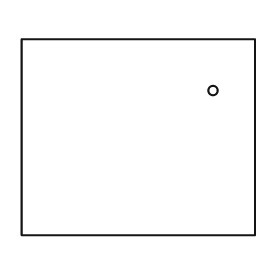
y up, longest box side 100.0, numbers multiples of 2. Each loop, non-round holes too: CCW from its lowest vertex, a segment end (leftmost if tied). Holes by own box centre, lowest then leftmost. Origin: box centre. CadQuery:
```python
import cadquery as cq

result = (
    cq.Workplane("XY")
    .moveTo(-50.0, -42.0)
    .lineTo(50.0, -42.0)
    .lineTo(50.0, 42.0)
    .lineTo(-50.0, 42.0)
    .close()
    .moveTo(32.0, 20.0)
    .circle(2.0)
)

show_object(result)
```